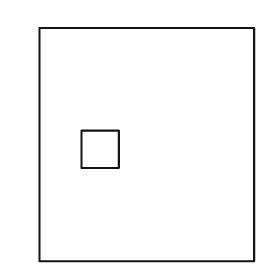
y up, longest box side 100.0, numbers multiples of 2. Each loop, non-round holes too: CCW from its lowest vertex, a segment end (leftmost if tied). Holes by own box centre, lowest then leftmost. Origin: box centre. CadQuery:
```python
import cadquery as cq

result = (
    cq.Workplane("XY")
    .moveTo(-46.0, -50.0)
    .lineTo(46.0, -50.0)
    .lineTo(46.0, 50.0)
    .lineTo(-46.0, 50.0)
    .close()
    .moveTo(-28.0, -10.0)
    .lineTo(-12.0, -10.0)
    .lineTo(-12.0, 6.0)
    .lineTo(-28.0, 6.0)
    .close()
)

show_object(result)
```